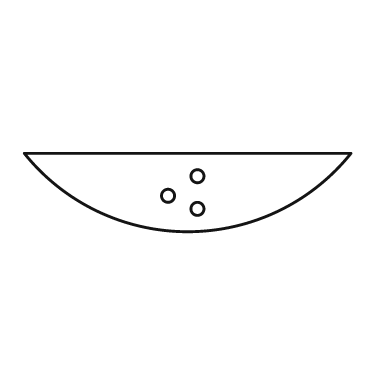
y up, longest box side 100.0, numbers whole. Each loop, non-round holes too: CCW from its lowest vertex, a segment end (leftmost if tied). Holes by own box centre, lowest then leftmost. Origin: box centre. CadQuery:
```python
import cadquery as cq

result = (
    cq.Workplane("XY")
    .moveTo(-50.0, 12.0)
    .threePointArc((0.0, -12.0), (50.0, 12.0))
    .close()
    .moveTo(3.0, -5.0)
    .circle(2.0)
    .moveTo(-6.0, -1.0)
    .circle(2.0)
    .moveTo(3.0, 5.0)
    .circle(2.0)
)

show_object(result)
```